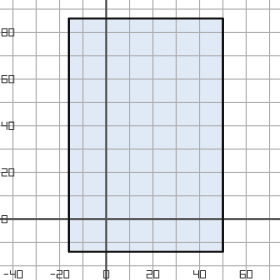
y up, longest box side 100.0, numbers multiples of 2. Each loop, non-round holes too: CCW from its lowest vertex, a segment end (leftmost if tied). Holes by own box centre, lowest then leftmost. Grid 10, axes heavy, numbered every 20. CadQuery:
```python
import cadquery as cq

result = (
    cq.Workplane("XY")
    .moveTo(-16.0, -14.0)
    .lineTo(50.0, -14.0)
    .lineTo(50.0, 86.0)
    .lineTo(-16.0, 86.0)
    .close()
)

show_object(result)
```